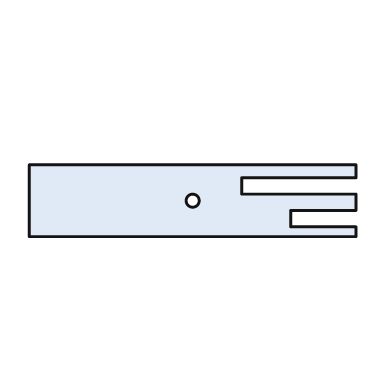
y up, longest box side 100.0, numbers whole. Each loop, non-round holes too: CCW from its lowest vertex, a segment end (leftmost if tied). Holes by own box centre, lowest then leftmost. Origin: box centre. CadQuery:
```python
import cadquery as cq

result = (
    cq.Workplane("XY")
    .moveTo(-50.0, -11.0)
    .lineTo(50.0, -11.0)
    .lineTo(50.0, -8.0)
    .lineTo(30.0, -8.0)
    .lineTo(30.0, -3.0)
    .lineTo(50.0, -3.0)
    .lineTo(50.0, 2.0)
    .lineTo(15.0, 2.0)
    .lineTo(15.0, 7.0)
    .lineTo(50.0, 7.0)
    .lineTo(50.0, 11.0)
    .lineTo(-50.0, 11.0)
    .close()
    .moveTo(0.0, 0.0)
    .circle(2.0)
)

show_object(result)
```